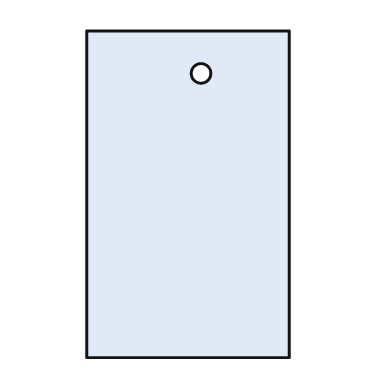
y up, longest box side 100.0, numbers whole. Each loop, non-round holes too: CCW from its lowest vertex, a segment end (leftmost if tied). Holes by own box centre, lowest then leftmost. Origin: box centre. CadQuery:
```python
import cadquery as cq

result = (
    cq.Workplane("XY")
    .moveTo(-31.0, -50.0)
    .lineTo(31.0, -50.0)
    .lineTo(31.0, 50.0)
    .lineTo(-31.0, 50.0)
    .close()
    .moveTo(4.0, 37.0)
    .circle(3.0)
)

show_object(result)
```